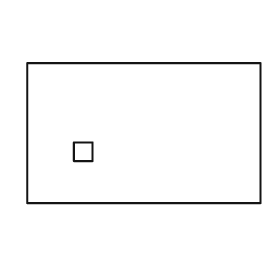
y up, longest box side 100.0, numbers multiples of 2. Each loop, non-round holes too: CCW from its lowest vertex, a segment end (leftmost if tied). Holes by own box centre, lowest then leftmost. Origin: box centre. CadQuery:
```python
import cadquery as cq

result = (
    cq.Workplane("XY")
    .moveTo(-50.0, -30.0)
    .lineTo(50.0, -30.0)
    .lineTo(50.0, 30.0)
    .lineTo(-50.0, 30.0)
    .close()
    .moveTo(-30.0, -12.0)
    .lineTo(-22.0, -12.0)
    .lineTo(-22.0, -4.0)
    .lineTo(-30.0, -4.0)
    .close()
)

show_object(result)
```